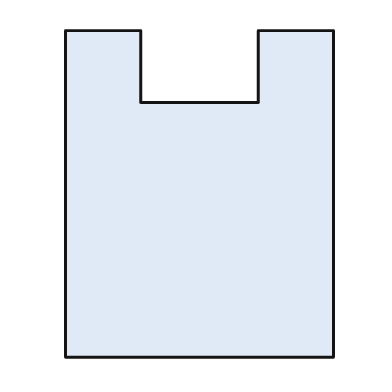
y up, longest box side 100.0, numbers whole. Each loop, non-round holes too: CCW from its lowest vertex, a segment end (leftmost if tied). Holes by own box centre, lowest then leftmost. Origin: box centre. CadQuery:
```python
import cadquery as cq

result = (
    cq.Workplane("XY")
    .moveTo(-41.0, -50.0)
    .lineTo(41.0, -50.0)
    .lineTo(41.0, 50.0)
    .lineTo(18.0, 50.0)
    .lineTo(18.0, 28.0)
    .lineTo(-18.0, 28.0)
    .lineTo(-18.0, 50.0)
    .lineTo(-41.0, 50.0)
    .close()
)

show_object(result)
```